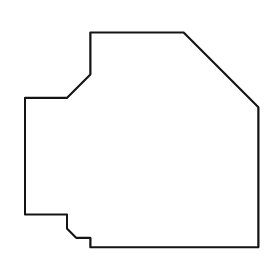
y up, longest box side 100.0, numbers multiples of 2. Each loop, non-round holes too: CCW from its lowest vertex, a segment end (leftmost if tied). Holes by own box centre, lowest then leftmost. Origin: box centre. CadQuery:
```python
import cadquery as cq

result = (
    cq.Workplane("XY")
    .moveTo(-22.0, -46.0)
    .lineTo(50.0, -46.0)
    .lineTo(50.0, 14.0)
    .lineTo(18.0, 46.0)
    .lineTo(-22.0, 46.0)
    .lineTo(-22.0, 28.0)
    .lineTo(-32.0, 18.0)
    .lineTo(-50.0, 18.0)
    .lineTo(-50.0, -32.0)
    .lineTo(-32.0, -32.0)
    .lineTo(-32.0, -38.0)
    .lineTo(-28.0, -42.0)
    .lineTo(-22.0, -42.0)
    .close()
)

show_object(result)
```